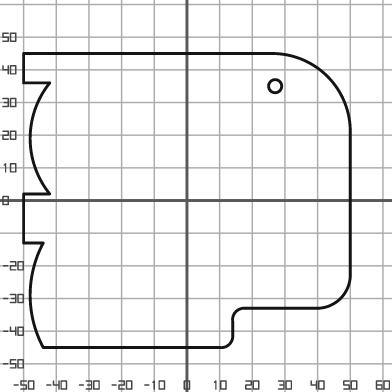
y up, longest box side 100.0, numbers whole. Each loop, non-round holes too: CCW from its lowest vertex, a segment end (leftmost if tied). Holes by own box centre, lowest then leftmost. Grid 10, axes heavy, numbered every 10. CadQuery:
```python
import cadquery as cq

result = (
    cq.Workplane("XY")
    .moveTo(-44.0, -45.0)
    .lineTo(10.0, -45.0)
    .threePointArc((13.0, -44.0), (14.0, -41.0))
    .lineTo(14.0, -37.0)
    .threePointArc((15.0, -34.0), (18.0, -33.0))
    .lineTo(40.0, -33.0)
    .threePointArc((47.0, -30.0), (50.0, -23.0))
    .lineTo(50.0, 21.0)
    .threePointArc((43.0, 38.0), (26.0, 45.0))
    .lineTo(-50.0, 45.0)
    .lineTo(-50.0, 36.0)
    .lineTo(-42.0, 36.0)
    .threePointArc((-48.0, 19.0), (-42.0, 2.0))
    .lineTo(-50.0, 2.0)
    .lineTo(-50.0, -13.0)
    .lineTo(-44.0, -13.0)
    .threePointArc((-48.0, -29.0), (-44.0, -45.0))
    .close()
    .moveTo(27.0, 35.0)
    .circle(2.0)
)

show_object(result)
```